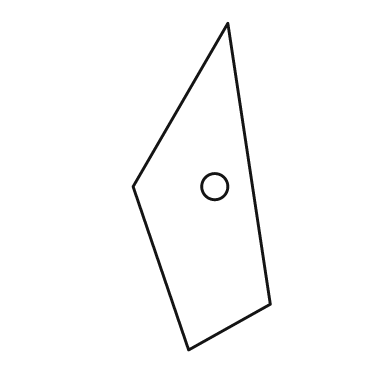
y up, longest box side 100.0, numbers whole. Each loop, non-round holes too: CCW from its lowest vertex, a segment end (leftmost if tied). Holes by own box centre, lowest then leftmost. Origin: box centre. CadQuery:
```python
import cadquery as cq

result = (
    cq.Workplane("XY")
    .moveTo(-4.0, -50.0)
    .lineTo(21.0, -36.0)
    .lineTo(8.0, 50.0)
    .lineTo(-21.0, 0.0)
    .close()
    .moveTo(4.0, 0.0)
    .circle(4.0)
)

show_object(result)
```